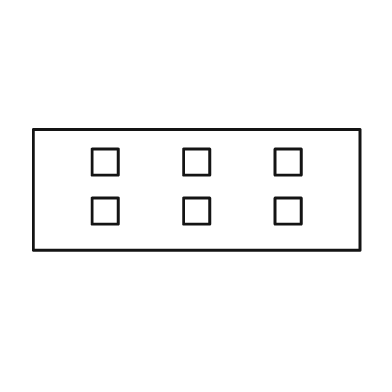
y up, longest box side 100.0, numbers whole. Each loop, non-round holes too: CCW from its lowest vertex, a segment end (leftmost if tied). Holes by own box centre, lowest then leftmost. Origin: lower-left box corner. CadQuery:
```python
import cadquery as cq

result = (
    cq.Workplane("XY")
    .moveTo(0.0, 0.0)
    .lineTo(100.0, 0.0)
    .lineTo(100.0, 37.0)
    .lineTo(0.0, 37.0)
    .close()
    .moveTo(18.0, 8.0)
    .lineTo(26.0, 8.0)
    .lineTo(26.0, 16.0)
    .lineTo(18.0, 16.0)
    .close()
    .moveTo(46.0, 8.0)
    .lineTo(54.0, 8.0)
    .lineTo(54.0, 16.0)
    .lineTo(46.0, 16.0)
    .close()
    .moveTo(74.0, 8.0)
    .lineTo(82.0, 8.0)
    .lineTo(82.0, 16.0)
    .lineTo(74.0, 16.0)
    .close()
    .moveTo(18.0, 23.0)
    .lineTo(26.0, 23.0)
    .lineTo(26.0, 31.0)
    .lineTo(18.0, 31.0)
    .close()
    .moveTo(46.0, 23.0)
    .lineTo(54.0, 23.0)
    .lineTo(54.0, 31.0)
    .lineTo(46.0, 31.0)
    .close()
    .moveTo(74.0, 23.0)
    .lineTo(82.0, 23.0)
    .lineTo(82.0, 31.0)
    .lineTo(74.0, 31.0)
    .close()
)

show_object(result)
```